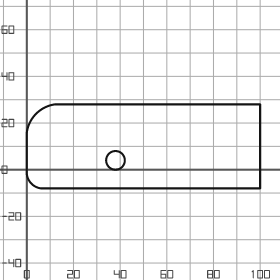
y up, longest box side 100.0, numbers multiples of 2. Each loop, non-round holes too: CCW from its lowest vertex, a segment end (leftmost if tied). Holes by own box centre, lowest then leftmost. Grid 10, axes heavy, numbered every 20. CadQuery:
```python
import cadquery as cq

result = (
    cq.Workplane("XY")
    .moveTo(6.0, -8.0)
    .lineTo(100.0, -8.0)
    .lineTo(100.0, 28.0)
    .lineTo(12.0, 28.0)
    .threePointArc((4.0, 24.0), (0.0, 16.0))
    .lineTo(0.0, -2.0)
    .threePointArc((2.0, -6.0), (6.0, -8.0))
    .close()
    .moveTo(38.0, 4.0)
    .circle(4.0)
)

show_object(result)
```